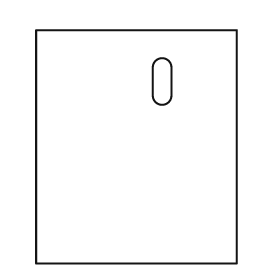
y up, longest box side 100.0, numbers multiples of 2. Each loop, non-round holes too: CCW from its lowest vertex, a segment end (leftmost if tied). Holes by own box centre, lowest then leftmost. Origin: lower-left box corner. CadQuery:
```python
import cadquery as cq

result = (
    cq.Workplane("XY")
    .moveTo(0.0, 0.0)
    .lineTo(86.0, 0.0)
    .lineTo(86.0, 100.0)
    .lineTo(0.0, 100.0)
    .close()
    .moveTo(50.0, 72.0)
    .threePointArc((54.0, 68.0), (58.0, 72.0))
    .lineTo(58.0, 84.0)
    .threePointArc((54.0, 88.0), (50.0, 84.0))
    .close()
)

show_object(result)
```